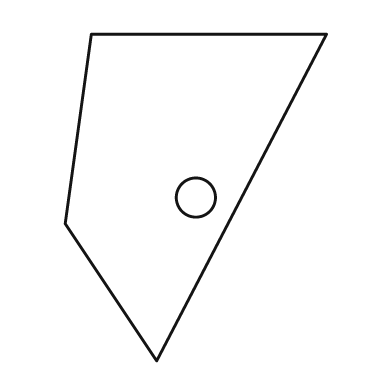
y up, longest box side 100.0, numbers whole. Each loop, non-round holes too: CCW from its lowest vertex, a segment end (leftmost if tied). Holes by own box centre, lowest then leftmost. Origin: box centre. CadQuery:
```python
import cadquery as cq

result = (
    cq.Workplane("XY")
    .moveTo(-12.0, -50.0)
    .lineTo(40.0, 50.0)
    .lineTo(-32.0, 50.0)
    .lineTo(-40.0, -8.0)
    .close()
    .moveTo(0.0, 0.0)
    .circle(6.0)
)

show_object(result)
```